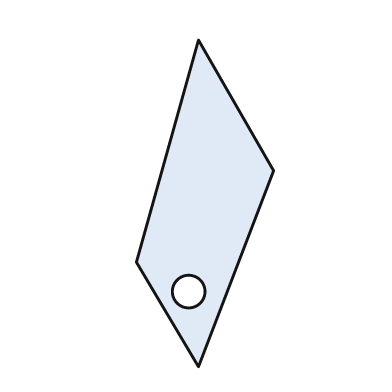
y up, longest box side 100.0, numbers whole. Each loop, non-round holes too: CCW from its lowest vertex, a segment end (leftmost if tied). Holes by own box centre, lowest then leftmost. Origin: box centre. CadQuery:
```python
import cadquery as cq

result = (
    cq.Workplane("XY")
    .moveTo(-2.0, -50.0)
    .lineTo(21.0, 10.0)
    .lineTo(-2.0, 50.0)
    .lineTo(-21.0, -18.0)
    .close()
    .moveTo(-5.0, -27.0)
    .circle(5.0)
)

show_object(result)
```